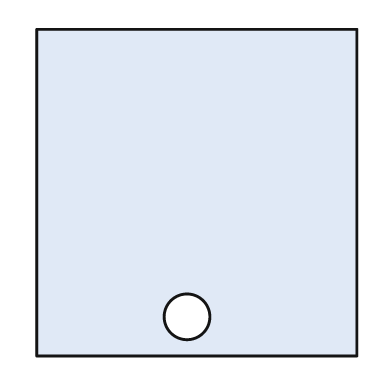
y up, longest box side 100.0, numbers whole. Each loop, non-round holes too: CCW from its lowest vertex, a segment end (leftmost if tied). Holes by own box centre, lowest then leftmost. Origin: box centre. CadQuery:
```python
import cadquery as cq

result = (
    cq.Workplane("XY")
    .moveTo(-49.0, -50.0)
    .lineTo(49.0, -50.0)
    .lineTo(49.0, 50.0)
    .lineTo(-49.0, 50.0)
    .close()
    .moveTo(-3.0, -38.0)
    .circle(7.0)
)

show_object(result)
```